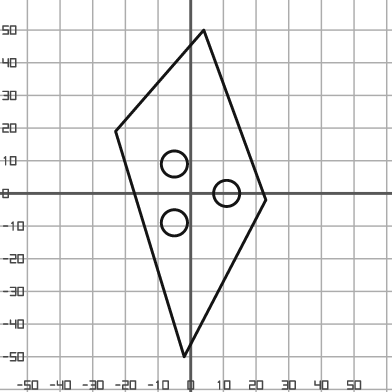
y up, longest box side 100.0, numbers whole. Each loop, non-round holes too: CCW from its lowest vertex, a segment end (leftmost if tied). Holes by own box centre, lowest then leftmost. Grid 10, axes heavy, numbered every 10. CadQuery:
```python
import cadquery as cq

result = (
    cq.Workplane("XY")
    .moveTo(-2.0, -50.0)
    .lineTo(23.0, -2.0)
    .lineTo(4.0, 50.0)
    .lineTo(-23.0, 19.0)
    .close()
    .moveTo(-5.0, -9.0)
    .circle(4.0)
    .moveTo(11.0, 0.0)
    .circle(4.0)
    .moveTo(-5.0, 9.0)
    .circle(4.0)
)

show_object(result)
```